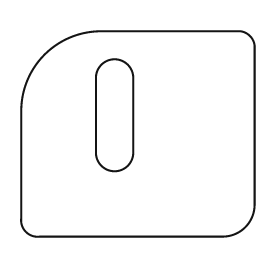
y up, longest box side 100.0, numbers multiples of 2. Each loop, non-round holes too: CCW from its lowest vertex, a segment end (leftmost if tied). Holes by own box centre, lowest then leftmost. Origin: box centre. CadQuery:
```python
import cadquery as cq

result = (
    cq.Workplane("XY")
    .moveTo(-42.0, -44.0)
    .lineTo(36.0, -44.0)
    .threePointArc((46.0, -40.0), (50.0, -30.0))
    .lineTo(50.0, 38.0)
    .threePointArc((48.0, 42.0), (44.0, 44.0))
    .lineTo(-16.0, 44.0)
    .threePointArc((-40.0, 34.0), (-50.0, 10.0))
    .lineTo(-50.0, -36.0)
    .threePointArc((-48.0, -42.0), (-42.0, -44.0))
    .close()
    .moveTo(-18.0, -8.0)
    .threePointArc((-10.0, -16.0), (-2.0, -8.0))
    .lineTo(-2.0, 24.0)
    .threePointArc((-10.0, 32.0), (-18.0, 24.0))
    .close()
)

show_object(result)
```